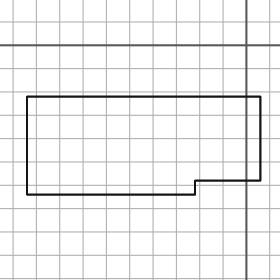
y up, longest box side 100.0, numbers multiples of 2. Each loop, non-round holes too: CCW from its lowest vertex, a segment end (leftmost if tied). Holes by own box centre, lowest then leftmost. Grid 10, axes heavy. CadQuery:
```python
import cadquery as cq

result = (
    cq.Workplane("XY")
    .moveTo(-94.0, -64.0)
    .lineTo(-22.0, -64.0)
    .lineTo(-22.0, -58.0)
    .lineTo(6.0, -58.0)
    .lineTo(6.0, -22.0)
    .lineTo(-94.0, -22.0)
    .close()
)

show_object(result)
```